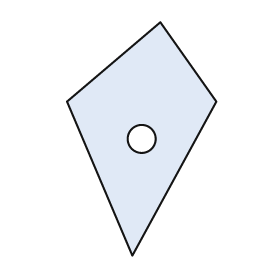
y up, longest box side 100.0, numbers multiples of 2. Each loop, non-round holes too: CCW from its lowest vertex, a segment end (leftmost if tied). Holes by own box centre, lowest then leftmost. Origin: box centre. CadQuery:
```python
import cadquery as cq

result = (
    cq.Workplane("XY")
    .moveTo(-4.0, -50.0)
    .lineTo(32.0, 16.0)
    .lineTo(8.0, 50.0)
    .lineTo(-32.0, 16.0)
    .close()
    .moveTo(0.0, 0.0)
    .circle(6.0)
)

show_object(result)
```